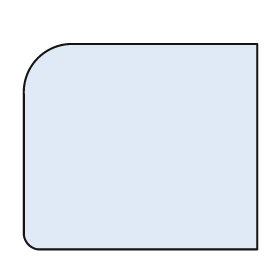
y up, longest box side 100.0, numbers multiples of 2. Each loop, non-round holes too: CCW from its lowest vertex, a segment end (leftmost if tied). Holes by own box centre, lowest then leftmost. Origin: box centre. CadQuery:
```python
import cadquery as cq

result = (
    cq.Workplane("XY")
    .moveTo(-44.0, -44.0)
    .lineTo(50.0, -44.0)
    .lineTo(50.0, 44.0)
    .lineTo(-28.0, 44.0)
    .threePointArc((-44.0, 38.0), (-50.0, 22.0))
    .lineTo(-50.0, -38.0)
    .threePointArc((-48.0, -42.0), (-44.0, -44.0))
    .close()
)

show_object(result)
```